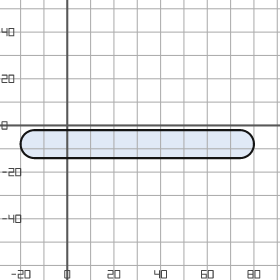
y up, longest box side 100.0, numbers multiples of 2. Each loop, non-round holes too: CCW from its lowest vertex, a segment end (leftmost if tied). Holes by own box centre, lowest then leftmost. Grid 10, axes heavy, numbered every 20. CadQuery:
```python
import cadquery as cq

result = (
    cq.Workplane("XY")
    .moveTo(-14.0, -14.0)
    .lineTo(74.0, -14.0)
    .threePointArc((80.0, -8.0), (74.0, -2.0))
    .lineTo(-14.0, -2.0)
    .threePointArc((-20.0, -8.0), (-14.0, -14.0))
    .close()
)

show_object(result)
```